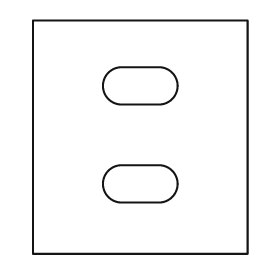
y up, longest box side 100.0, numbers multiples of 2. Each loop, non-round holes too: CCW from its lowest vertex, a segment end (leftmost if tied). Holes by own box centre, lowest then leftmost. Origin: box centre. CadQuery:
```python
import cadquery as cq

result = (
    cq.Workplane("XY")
    .moveTo(-46.0, -50.0)
    .lineTo(46.0, -50.0)
    .lineTo(46.0, 50.0)
    .lineTo(-46.0, 50.0)
    .close()
    .moveTo(-8.0, -28.0)
    .lineTo(8.0, -28.0)
    .threePointArc((16.0, -20.0), (8.0, -12.0))
    .lineTo(-8.0, -12.0)
    .threePointArc((-16.0, -20.0), (-8.0, -28.0))
    .close()
    .moveTo(-8.0, 14.0)
    .lineTo(8.0, 14.0)
    .threePointArc((16.0, 22.0), (8.0, 30.0))
    .lineTo(-8.0, 30.0)
    .threePointArc((-16.0, 22.0), (-8.0, 14.0))
    .close()
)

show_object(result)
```